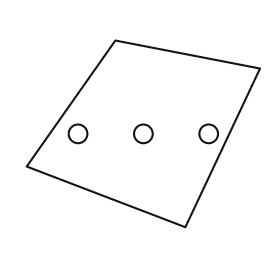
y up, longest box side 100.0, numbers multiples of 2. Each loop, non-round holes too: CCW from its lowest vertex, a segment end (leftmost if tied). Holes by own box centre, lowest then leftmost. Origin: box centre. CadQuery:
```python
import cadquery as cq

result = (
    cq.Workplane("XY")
    .moveTo(18.0, -40.0)
    .lineTo(50.0, 28.0)
    .lineTo(-12.0, 40.0)
    .lineTo(-50.0, -14.0)
    .close()
    .moveTo(-28.0, 0.0)
    .circle(4.0)
    .moveTo(0.0, 0.0)
    .circle(4.0)
    .moveTo(28.0, 0.0)
    .circle(4.0)
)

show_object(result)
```